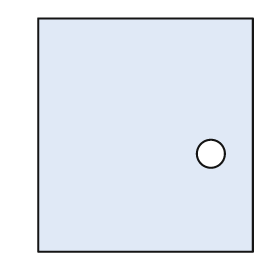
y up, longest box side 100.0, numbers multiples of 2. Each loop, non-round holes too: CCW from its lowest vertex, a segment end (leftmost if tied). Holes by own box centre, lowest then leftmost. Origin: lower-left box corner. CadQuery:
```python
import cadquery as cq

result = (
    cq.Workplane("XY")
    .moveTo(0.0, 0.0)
    .lineTo(92.0, 0.0)
    .lineTo(92.0, 100.0)
    .lineTo(0.0, 100.0)
    .close()
    .moveTo(74.0, 42.0)
    .circle(6.0)
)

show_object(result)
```